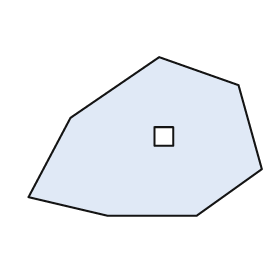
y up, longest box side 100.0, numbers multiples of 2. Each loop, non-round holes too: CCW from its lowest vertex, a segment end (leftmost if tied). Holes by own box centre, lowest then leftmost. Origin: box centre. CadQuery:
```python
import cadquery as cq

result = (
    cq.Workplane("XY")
    .moveTo(-16.0, -34.0)
    .lineTo(22.0, -34.0)
    .lineTo(50.0, -14.0)
    .lineTo(40.0, 22.0)
    .lineTo(6.0, 34.0)
    .lineTo(-32.0, 8.0)
    .lineTo(-50.0, -26.0)
    .close()
    .moveTo(4.0, -4.0)
    .lineTo(12.0, -4.0)
    .lineTo(12.0, 4.0)
    .lineTo(4.0, 4.0)
    .close()
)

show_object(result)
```